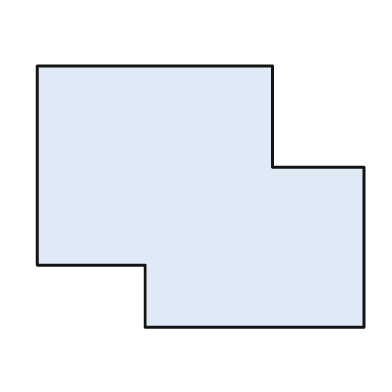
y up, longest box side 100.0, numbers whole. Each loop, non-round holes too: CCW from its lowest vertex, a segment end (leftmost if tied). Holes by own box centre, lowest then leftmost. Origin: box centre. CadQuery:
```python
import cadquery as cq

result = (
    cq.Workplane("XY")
    .moveTo(-17.0, -40.0)
    .lineTo(50.0, -40.0)
    .lineTo(50.0, 9.0)
    .lineTo(22.0, 9.0)
    .lineTo(22.0, 40.0)
    .lineTo(-50.0, 40.0)
    .lineTo(-50.0, -21.0)
    .lineTo(-17.0, -21.0)
    .close()
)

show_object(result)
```